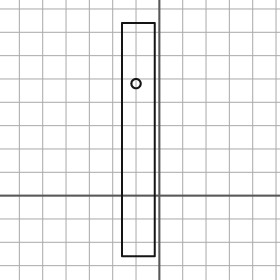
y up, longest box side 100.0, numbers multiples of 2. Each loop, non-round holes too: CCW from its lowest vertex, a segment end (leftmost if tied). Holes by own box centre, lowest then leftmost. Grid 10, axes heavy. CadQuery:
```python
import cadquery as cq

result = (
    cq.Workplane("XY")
    .moveTo(-16.0, -26.0)
    .lineTo(-2.0, -26.0)
    .lineTo(-2.0, 74.0)
    .lineTo(-16.0, 74.0)
    .close()
    .moveTo(-10.0, 48.0)
    .circle(2.0)
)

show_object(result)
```